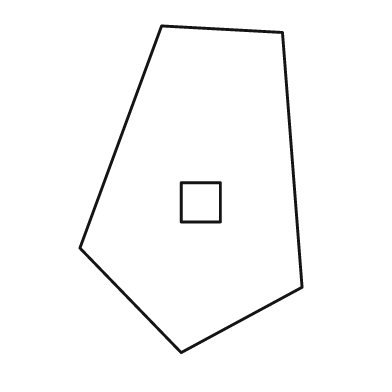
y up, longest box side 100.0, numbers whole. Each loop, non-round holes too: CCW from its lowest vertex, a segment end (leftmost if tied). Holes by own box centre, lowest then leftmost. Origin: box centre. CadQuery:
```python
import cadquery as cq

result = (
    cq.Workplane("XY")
    .moveTo(-3.0, -50.0)
    .lineTo(34.0, -30.0)
    .lineTo(28.0, 48.0)
    .lineTo(-9.0, 50.0)
    .lineTo(-34.0, -18.0)
    .close()
    .moveTo(-3.0, -10.0)
    .lineTo(9.0, -10.0)
    .lineTo(9.0, 2.0)
    .lineTo(-3.0, 2.0)
    .close()
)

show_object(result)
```